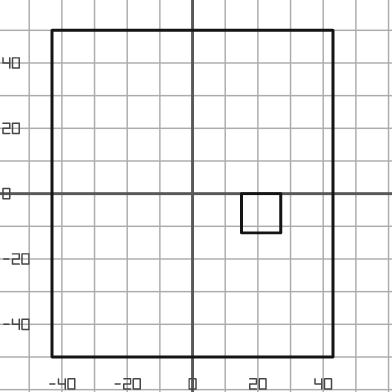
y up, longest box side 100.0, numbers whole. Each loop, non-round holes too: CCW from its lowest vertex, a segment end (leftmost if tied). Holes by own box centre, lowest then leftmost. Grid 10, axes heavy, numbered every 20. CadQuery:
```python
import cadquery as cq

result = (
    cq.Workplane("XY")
    .moveTo(-43.0, -50.0)
    .lineTo(43.0, -50.0)
    .lineTo(43.0, 50.0)
    .lineTo(-43.0, 50.0)
    .close()
    .moveTo(15.0, -12.0)
    .lineTo(27.0, -12.0)
    .lineTo(27.0, 0.0)
    .lineTo(15.0, 0.0)
    .close()
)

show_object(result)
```